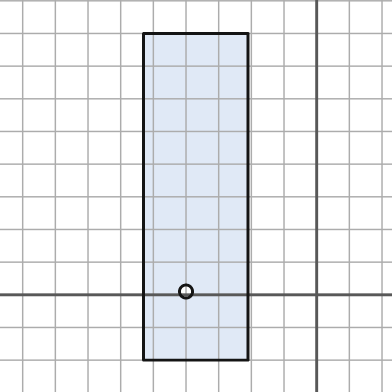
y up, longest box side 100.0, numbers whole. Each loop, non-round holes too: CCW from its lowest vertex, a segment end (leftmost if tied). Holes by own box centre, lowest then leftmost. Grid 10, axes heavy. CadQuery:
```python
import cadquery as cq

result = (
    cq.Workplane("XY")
    .moveTo(-53.0, -20.0)
    .lineTo(-21.0, -20.0)
    .lineTo(-21.0, 80.0)
    .lineTo(-53.0, 80.0)
    .close()
    .moveTo(-40.0, 1.0)
    .circle(2.0)
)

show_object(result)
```